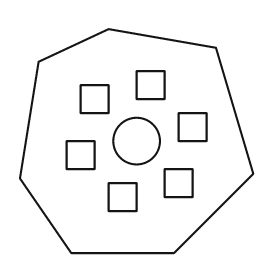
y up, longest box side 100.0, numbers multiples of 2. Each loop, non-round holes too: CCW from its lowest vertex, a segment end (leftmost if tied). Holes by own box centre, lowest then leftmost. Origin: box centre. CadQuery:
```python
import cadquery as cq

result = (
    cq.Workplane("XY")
    .moveTo(-28.0, -48.0)
    .lineTo(16.0, -48.0)
    .lineTo(50.0, -14.0)
    .lineTo(34.0, 40.0)
    .lineTo(-12.0, 48.0)
    .lineTo(-42.0, 34.0)
    .lineTo(-50.0, -16.0)
    .close()
    .moveTo(-12.0, -30.0)
    .lineTo(0.0, -30.0)
    .lineTo(0.0, -18.0)
    .lineTo(-12.0, -18.0)
    .close()
    .moveTo(12.0, -24.0)
    .lineTo(24.0, -24.0)
    .lineTo(24.0, -12.0)
    .lineTo(12.0, -12.0)
    .close()
    .moveTo(-30.0, -12.0)
    .lineTo(-18.0, -12.0)
    .lineTo(-18.0, 0.0)
    .lineTo(-30.0, 0.0)
    .close()
    .moveTo(0.0, 0.0)
    .circle(10.0)
    .moveTo(18.0, 0.0)
    .lineTo(30.0, 0.0)
    .lineTo(30.0, 12.0)
    .lineTo(18.0, 12.0)
    .close()
    .moveTo(-24.0, 12.0)
    .lineTo(-12.0, 12.0)
    .lineTo(-12.0, 24.0)
    .lineTo(-24.0, 24.0)
    .close()
    .moveTo(0.0, 18.0)
    .lineTo(12.0, 18.0)
    .lineTo(12.0, 30.0)
    .lineTo(0.0, 30.0)
    .close()
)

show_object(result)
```